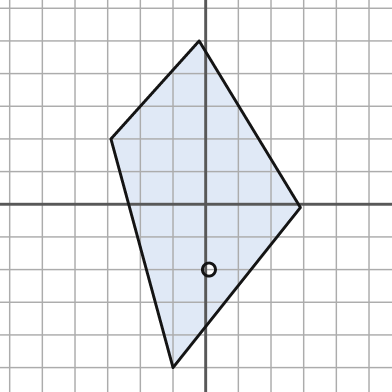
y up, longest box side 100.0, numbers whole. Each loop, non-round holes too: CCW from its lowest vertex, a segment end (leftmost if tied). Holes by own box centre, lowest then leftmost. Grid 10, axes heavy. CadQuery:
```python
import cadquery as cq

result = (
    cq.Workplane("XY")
    .moveTo(-10.0, -50.0)
    .lineTo(29.0, -1.0)
    .lineTo(-2.0, 50.0)
    .lineTo(-29.0, 20.0)
    .close()
    .moveTo(1.0, -20.0)
    .circle(2.0)
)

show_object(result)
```